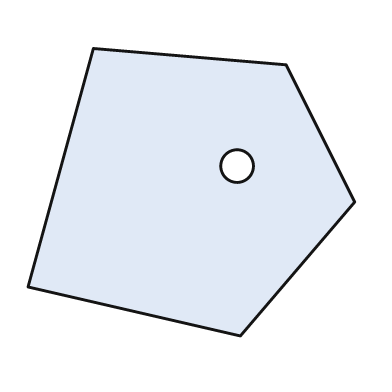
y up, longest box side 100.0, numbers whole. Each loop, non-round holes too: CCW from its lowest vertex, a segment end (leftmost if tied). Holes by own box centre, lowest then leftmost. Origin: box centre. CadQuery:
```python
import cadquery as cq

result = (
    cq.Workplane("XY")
    .moveTo(15.0, -44.0)
    .lineTo(50.0, -3.0)
    .lineTo(29.0, 39.0)
    .lineTo(-30.0, 44.0)
    .lineTo(-50.0, -29.0)
    .close()
    .moveTo(14.0, 8.0)
    .circle(5.0)
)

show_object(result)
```